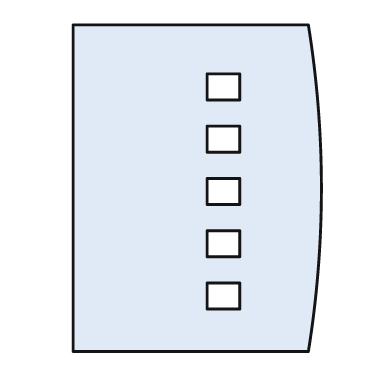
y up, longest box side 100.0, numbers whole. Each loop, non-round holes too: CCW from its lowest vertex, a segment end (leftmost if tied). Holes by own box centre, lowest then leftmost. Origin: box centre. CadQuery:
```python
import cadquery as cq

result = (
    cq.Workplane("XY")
    .moveTo(-38.0, -50.0)
    .lineTo(34.0, -50.0)
    .threePointArc((38.0, 0.0), (34.0, 50.0))
    .lineTo(-38.0, 50.0)
    .close()
    .moveTo(3.0, -37.0)
    .lineTo(13.0, -37.0)
    .lineTo(13.0, -29.0)
    .lineTo(3.0, -29.0)
    .close()
    .moveTo(3.0, -21.0)
    .lineTo(13.0, -21.0)
    .lineTo(13.0, -13.0)
    .lineTo(3.0, -13.0)
    .close()
    .moveTo(3.0, -5.0)
    .lineTo(13.0, -5.0)
    .lineTo(13.0, 3.0)
    .lineTo(3.0, 3.0)
    .close()
    .moveTo(3.0, 11.0)
    .lineTo(13.0, 11.0)
    .lineTo(13.0, 19.0)
    .lineTo(3.0, 19.0)
    .close()
    .moveTo(3.0, 27.0)
    .lineTo(13.0, 27.0)
    .lineTo(13.0, 35.0)
    .lineTo(3.0, 35.0)
    .close()
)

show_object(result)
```